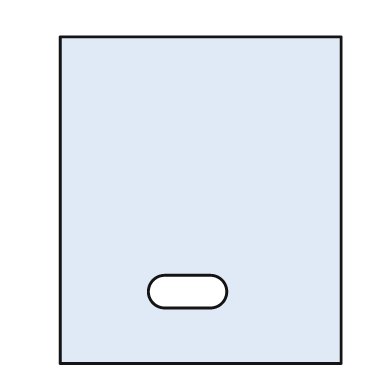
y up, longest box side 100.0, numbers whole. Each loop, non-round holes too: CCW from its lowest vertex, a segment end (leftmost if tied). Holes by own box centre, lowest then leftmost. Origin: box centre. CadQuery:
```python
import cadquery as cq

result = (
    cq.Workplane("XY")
    .moveTo(-43.0, -50.0)
    .lineTo(43.0, -50.0)
    .lineTo(43.0, 50.0)
    .lineTo(-43.0, 50.0)
    .close()
    .moveTo(-11.0, -33.0)
    .lineTo(3.0, -33.0)
    .threePointArc((8.0, -28.0), (3.0, -23.0))
    .lineTo(-11.0, -23.0)
    .threePointArc((-16.0, -28.0), (-11.0, -33.0))
    .close()
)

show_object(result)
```